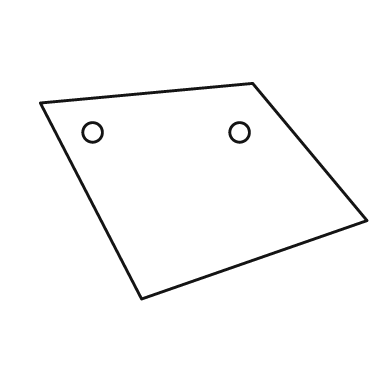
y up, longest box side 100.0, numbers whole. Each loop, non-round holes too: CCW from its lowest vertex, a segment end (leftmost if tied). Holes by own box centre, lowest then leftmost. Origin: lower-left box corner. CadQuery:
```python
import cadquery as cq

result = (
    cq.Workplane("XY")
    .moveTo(31.0, 0.0)
    .lineTo(100.0, 24.0)
    .lineTo(65.0, 66.0)
    .lineTo(0.0, 60.0)
    .close()
    .moveTo(16.0, 51.0)
    .circle(3.0)
    .moveTo(61.0, 51.0)
    .circle(3.0)
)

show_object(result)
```